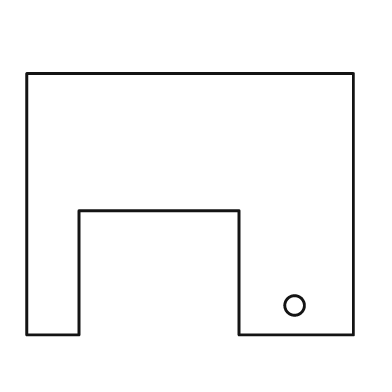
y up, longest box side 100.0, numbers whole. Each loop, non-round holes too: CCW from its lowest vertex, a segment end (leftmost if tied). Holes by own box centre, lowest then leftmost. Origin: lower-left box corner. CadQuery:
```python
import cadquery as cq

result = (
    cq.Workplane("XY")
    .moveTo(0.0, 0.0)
    .lineTo(16.0, 0.0)
    .lineTo(16.0, 38.0)
    .lineTo(65.0, 38.0)
    .lineTo(65.0, 0.0)
    .lineTo(100.0, 0.0)
    .lineTo(100.0, 80.0)
    .lineTo(0.0, 80.0)
    .close()
    .moveTo(82.0, 9.0)
    .circle(3.0)
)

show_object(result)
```